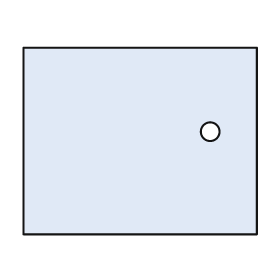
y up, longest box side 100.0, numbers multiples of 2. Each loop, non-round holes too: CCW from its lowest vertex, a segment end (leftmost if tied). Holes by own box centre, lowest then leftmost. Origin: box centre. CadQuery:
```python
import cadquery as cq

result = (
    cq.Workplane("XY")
    .moveTo(-50.0, -40.0)
    .lineTo(50.0, -40.0)
    .lineTo(50.0, 40.0)
    .lineTo(-50.0, 40.0)
    .close()
    .moveTo(30.0, 4.0)
    .circle(4.0)
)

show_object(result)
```